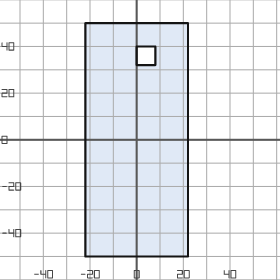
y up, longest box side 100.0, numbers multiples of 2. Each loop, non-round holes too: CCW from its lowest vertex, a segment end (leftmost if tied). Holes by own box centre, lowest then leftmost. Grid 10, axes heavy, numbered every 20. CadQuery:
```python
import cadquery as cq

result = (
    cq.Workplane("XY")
    .moveTo(-22.0, -50.0)
    .lineTo(22.0, -50.0)
    .lineTo(22.0, 50.0)
    .lineTo(-22.0, 50.0)
    .close()
    .moveTo(0.0, 32.0)
    .lineTo(8.0, 32.0)
    .lineTo(8.0, 40.0)
    .lineTo(0.0, 40.0)
    .close()
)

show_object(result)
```